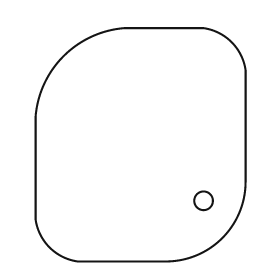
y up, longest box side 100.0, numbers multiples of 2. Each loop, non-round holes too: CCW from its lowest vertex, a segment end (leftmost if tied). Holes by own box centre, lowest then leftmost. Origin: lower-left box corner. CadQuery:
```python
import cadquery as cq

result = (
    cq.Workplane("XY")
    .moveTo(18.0, 0.0)
    .lineTo(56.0, 0.0)
    .threePointArc((80.0, 10.0), (90.0, 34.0))
    .lineTo(90.0, 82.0)
    .threePointArc((84.0, 94.0), (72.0, 100.0))
    .lineTo(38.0, 100.0)
    .threePointArc((12.0, 88.0), (0.0, 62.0))
    .lineTo(0.0, 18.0)
    .threePointArc((6.0, 6.0), (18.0, 0.0))
    .close()
    .moveTo(72.0, 26.0)
    .circle(4.0)
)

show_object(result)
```